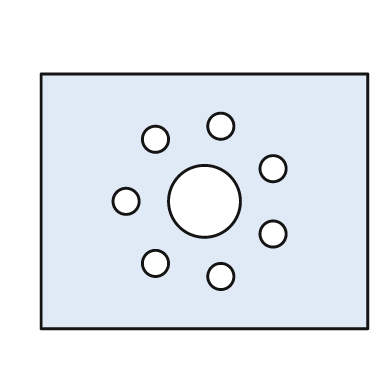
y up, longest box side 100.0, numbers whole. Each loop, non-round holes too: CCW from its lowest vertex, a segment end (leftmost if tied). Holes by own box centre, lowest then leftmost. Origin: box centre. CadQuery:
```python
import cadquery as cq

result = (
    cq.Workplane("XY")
    .moveTo(-50.0, -39.0)
    .lineTo(50.0, -39.0)
    .lineTo(50.0, 39.0)
    .lineTo(-50.0, 39.0)
    .close()
    .moveTo(5.0, -23.0)
    .circle(4.0)
    .moveTo(-15.0, -19.0)
    .circle(4.0)
    .moveTo(21.0, -10.0)
    .circle(4.0)
    .moveTo(-24.0, 0.0)
    .circle(4.0)
    .moveTo(0.0, 0.0)
    .circle(11.0)
    .moveTo(21.0, 10.0)
    .circle(4.0)
    .moveTo(-15.0, 19.0)
    .circle(4.0)
    .moveTo(5.0, 23.0)
    .circle(4.0)
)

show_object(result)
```